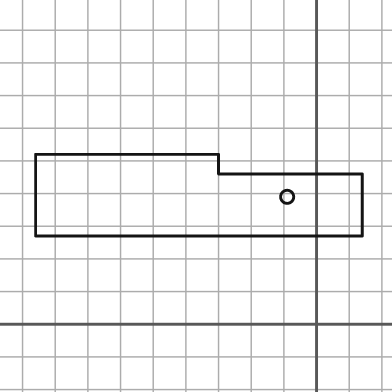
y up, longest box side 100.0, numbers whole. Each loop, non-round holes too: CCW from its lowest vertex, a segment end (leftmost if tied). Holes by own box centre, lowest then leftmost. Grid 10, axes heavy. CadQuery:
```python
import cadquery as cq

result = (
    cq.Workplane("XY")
    .moveTo(-86.0, 27.0)
    .lineTo(14.0, 27.0)
    .lineTo(14.0, 46.0)
    .lineTo(-30.0, 46.0)
    .lineTo(-30.0, 52.0)
    .lineTo(-86.0, 52.0)
    .close()
    .moveTo(-9.0, 39.0)
    .circle(2.0)
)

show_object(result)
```